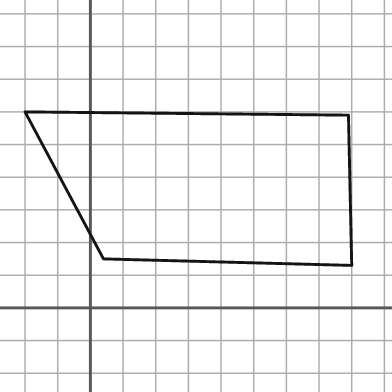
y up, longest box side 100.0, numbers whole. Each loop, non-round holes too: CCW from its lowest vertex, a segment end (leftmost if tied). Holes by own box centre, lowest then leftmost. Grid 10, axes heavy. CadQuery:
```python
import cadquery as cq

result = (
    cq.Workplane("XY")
    .moveTo(80.0, 13.0)
    .lineTo(79.0, 59.0)
    .lineTo(-20.0, 60.0)
    .lineTo(4.0, 15.0)
    .close()
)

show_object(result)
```